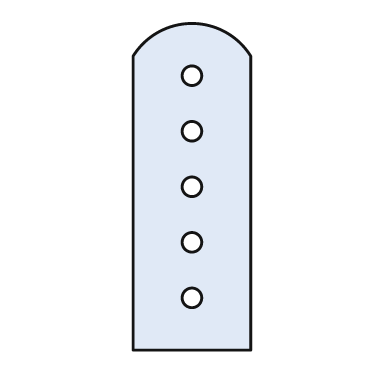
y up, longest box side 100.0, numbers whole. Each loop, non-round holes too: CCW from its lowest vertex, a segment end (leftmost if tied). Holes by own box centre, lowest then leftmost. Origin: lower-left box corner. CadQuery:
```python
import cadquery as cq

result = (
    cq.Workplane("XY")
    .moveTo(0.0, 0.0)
    .lineTo(36.0, 0.0)
    .lineTo(36.0, 90.0)
    .threePointArc((18.0, 100.0), (0.0, 90.0))
    .close()
    .moveTo(18.0, 16.0)
    .circle(3.0)
    .moveTo(18.0, 33.0)
    .circle(3.0)
    .moveTo(18.0, 50.0)
    .circle(3.0)
    .moveTo(18.0, 67.0)
    .circle(3.0)
    .moveTo(18.0, 84.0)
    .circle(3.0)
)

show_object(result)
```